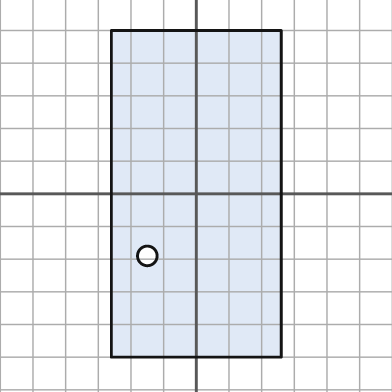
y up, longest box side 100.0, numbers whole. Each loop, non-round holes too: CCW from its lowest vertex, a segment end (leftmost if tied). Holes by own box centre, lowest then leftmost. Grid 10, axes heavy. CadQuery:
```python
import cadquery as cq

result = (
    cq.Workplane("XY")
    .moveTo(-26.0, -50.0)
    .lineTo(26.0, -50.0)
    .lineTo(26.0, 50.0)
    .lineTo(-26.0, 50.0)
    .close()
    .moveTo(-15.0, -19.0)
    .circle(3.0)
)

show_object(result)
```